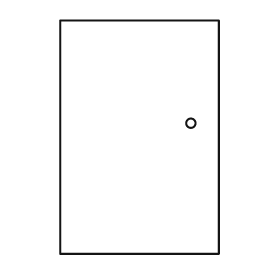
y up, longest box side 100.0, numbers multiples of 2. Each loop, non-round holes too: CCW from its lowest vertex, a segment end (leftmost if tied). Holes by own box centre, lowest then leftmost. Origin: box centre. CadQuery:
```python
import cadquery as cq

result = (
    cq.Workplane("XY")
    .moveTo(-34.0, -50.0)
    .lineTo(34.0, -50.0)
    .lineTo(34.0, 50.0)
    .lineTo(-34.0, 50.0)
    .close()
    .moveTo(22.0, 6.0)
    .circle(2.0)
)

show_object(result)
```